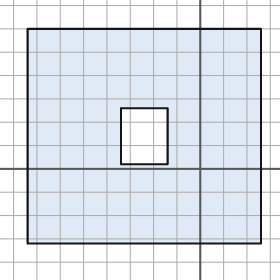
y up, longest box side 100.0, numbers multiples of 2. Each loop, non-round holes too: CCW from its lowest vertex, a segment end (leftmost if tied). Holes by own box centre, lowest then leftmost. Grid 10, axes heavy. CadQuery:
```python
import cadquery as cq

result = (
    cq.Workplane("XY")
    .moveTo(-74.0, -32.0)
    .lineTo(26.0, -32.0)
    .lineTo(26.0, 60.0)
    .lineTo(-74.0, 60.0)
    .close()
    .moveTo(-34.0, 2.0)
    .lineTo(-14.0, 2.0)
    .lineTo(-14.0, 26.0)
    .lineTo(-34.0, 26.0)
    .close()
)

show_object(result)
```